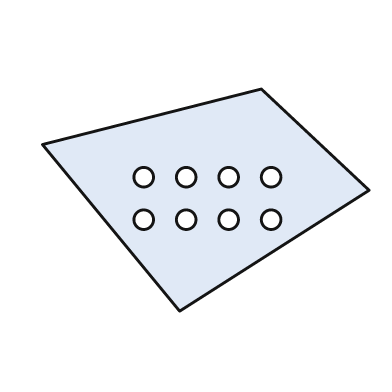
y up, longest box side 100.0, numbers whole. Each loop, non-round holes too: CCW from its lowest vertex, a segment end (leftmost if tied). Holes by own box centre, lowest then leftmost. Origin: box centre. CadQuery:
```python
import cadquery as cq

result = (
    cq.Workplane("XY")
    .moveTo(-8.0, -34.0)
    .lineTo(50.0, 3.0)
    .lineTo(17.0, 34.0)
    .lineTo(-50.0, 17.0)
    .close()
    .moveTo(-19.0, -6.0)
    .circle(3.0)
    .moveTo(-6.0, -6.0)
    .circle(3.0)
    .moveTo(7.0, -6.0)
    .circle(3.0)
    .moveTo(20.0, -6.0)
    .circle(3.0)
    .moveTo(-19.0, 7.0)
    .circle(3.0)
    .moveTo(-6.0, 7.0)
    .circle(3.0)
    .moveTo(7.0, 7.0)
    .circle(3.0)
    .moveTo(20.0, 7.0)
    .circle(3.0)
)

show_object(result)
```